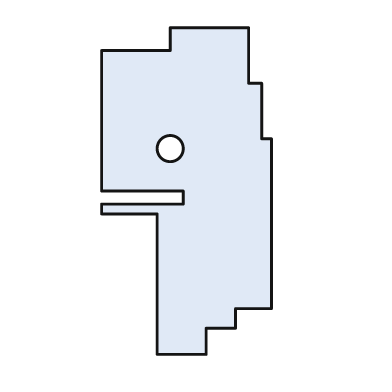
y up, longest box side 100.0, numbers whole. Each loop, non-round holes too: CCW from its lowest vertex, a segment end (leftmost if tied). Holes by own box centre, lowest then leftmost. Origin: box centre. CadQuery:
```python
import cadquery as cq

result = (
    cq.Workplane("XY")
    .moveTo(-9.0, -50.0)
    .lineTo(6.0, -50.0)
    .lineTo(6.0, -42.0)
    .lineTo(15.0, -42.0)
    .lineTo(15.0, -36.0)
    .lineTo(26.0, -36.0)
    .lineTo(26.0, 16.0)
    .lineTo(23.0, 16.0)
    .lineTo(23.0, 33.0)
    .lineTo(19.0, 33.0)
    .lineTo(19.0, 50.0)
    .lineTo(-5.0, 50.0)
    .lineTo(-5.0, 43.0)
    .lineTo(-26.0, 43.0)
    .lineTo(-26.0, 0.0)
    .lineTo(-1.0, 0.0)
    .lineTo(-1.0, -4.0)
    .lineTo(-26.0, -4.0)
    .lineTo(-26.0, -7.0)
    .lineTo(-9.0, -7.0)
    .close()
    .moveTo(-5.0, 13.0)
    .circle(4.0)
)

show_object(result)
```